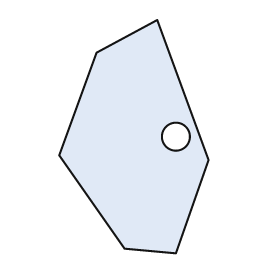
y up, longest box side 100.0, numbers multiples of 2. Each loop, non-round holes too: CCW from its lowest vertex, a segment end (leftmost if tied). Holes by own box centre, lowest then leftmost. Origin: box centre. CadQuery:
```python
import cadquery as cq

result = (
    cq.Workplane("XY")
    .moveTo(18.0, -50.0)
    .lineTo(32.0, -10.0)
    .lineTo(10.0, 50.0)
    .lineTo(-16.0, 36.0)
    .lineTo(-32.0, -8.0)
    .lineTo(-4.0, -48.0)
    .close()
    .moveTo(18.0, 0.0)
    .circle(6.0)
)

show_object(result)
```